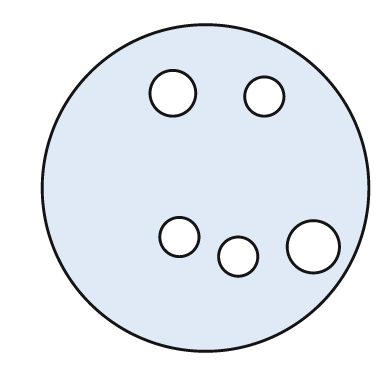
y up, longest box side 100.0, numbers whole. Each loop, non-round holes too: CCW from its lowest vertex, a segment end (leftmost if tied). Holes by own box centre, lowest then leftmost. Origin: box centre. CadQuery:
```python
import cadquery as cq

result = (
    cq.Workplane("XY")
    .moveTo(0.0, 0.0)
    .circle(50.0)
    .moveTo(10.0, -21.0)
    .circle(6.0)
    .moveTo(33.0, -18.0)
    .circle(8.0)
    .moveTo(-8.0, -15.0)
    .circle(6.0)
    .moveTo(18.0, 28.0)
    .circle(6.0)
    .moveTo(-10.0, 29.0)
    .circle(7.0)
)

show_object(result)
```